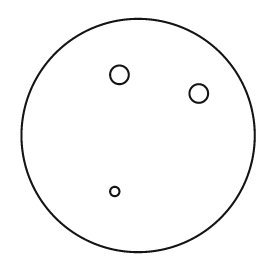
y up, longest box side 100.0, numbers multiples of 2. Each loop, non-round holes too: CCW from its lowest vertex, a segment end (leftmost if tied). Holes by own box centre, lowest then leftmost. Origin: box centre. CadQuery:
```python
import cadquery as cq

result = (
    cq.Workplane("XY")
    .moveTo(0.0, 0.0)
    .circle(50.0)
    .moveTo(-10.0, -24.0)
    .circle(2.0)
    .moveTo(26.0, 18.0)
    .circle(4.0)
    .moveTo(-8.0, 26.0)
    .circle(4.0)
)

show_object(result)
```